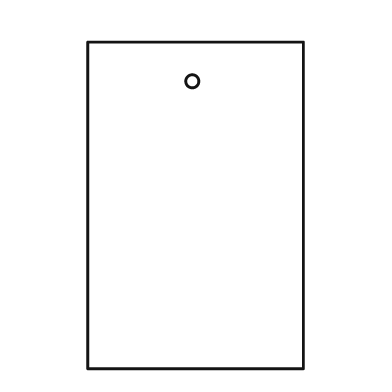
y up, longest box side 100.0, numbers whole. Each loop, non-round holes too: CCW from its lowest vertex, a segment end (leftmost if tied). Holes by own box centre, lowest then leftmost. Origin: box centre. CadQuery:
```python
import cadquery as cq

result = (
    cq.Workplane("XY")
    .moveTo(-33.0, -50.0)
    .lineTo(33.0, -50.0)
    .lineTo(33.0, 50.0)
    .lineTo(-33.0, 50.0)
    .close()
    .moveTo(-1.0, 38.0)
    .circle(2.0)
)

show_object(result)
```